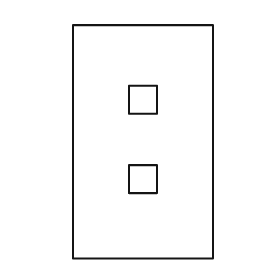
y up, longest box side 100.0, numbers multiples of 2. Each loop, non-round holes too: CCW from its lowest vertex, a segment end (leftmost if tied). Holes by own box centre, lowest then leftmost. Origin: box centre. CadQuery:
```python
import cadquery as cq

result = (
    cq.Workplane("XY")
    .moveTo(-30.0, -50.0)
    .lineTo(30.0, -50.0)
    .lineTo(30.0, 50.0)
    .lineTo(-30.0, 50.0)
    .close()
    .moveTo(-6.0, -22.0)
    .lineTo(6.0, -22.0)
    .lineTo(6.0, -10.0)
    .lineTo(-6.0, -10.0)
    .close()
    .moveTo(-6.0, 12.0)
    .lineTo(6.0, 12.0)
    .lineTo(6.0, 24.0)
    .lineTo(-6.0, 24.0)
    .close()
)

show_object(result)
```